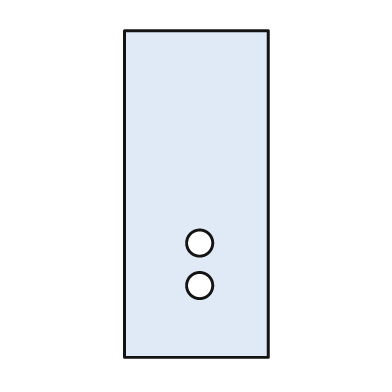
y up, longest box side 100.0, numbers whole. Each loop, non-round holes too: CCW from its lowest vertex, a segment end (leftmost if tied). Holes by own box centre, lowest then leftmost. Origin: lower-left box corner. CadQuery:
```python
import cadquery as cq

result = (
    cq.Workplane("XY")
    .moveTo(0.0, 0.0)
    .lineTo(44.0, 0.0)
    .lineTo(44.0, 100.0)
    .lineTo(0.0, 100.0)
    .close()
    .moveTo(23.0, 22.0)
    .circle(4.0)
    .moveTo(23.0, 35.0)
    .circle(4.0)
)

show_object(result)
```